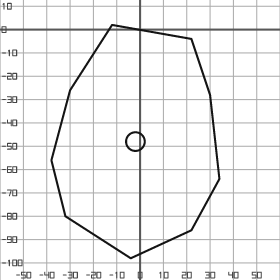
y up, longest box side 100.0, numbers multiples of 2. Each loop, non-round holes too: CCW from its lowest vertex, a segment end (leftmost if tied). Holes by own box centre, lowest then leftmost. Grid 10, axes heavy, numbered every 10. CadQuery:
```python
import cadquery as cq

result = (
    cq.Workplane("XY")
    .moveTo(-4.0, -98.0)
    .lineTo(22.0, -86.0)
    .lineTo(34.0, -64.0)
    .lineTo(30.0, -28.0)
    .lineTo(22.0, -4.0)
    .lineTo(-12.0, 2.0)
    .lineTo(-30.0, -26.0)
    .lineTo(-38.0, -56.0)
    .lineTo(-32.0, -80.0)
    .close()
    .moveTo(-2.0, -48.0)
    .circle(4.0)
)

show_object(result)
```